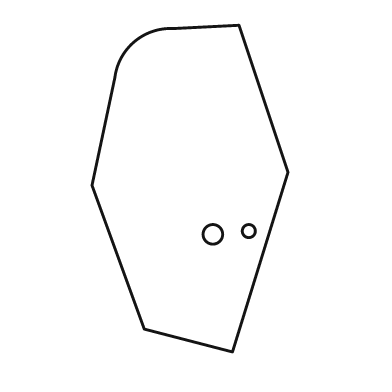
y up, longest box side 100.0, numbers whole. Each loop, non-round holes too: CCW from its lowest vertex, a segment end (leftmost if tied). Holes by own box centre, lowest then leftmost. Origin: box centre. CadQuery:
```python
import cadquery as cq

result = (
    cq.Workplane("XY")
    .moveTo(13.0, -50.0)
    .lineTo(30.0, 5.0)
    .lineTo(15.0, 50.0)
    .lineTo(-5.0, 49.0)
    .threePointArc((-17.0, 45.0), (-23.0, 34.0))
    .lineTo(-30.0, 1.0)
    .lineTo(-14.0, -43.0)
    .close()
    .moveTo(7.0, -14.0)
    .circle(3.0)
    .moveTo(18.0, -13.0)
    .circle(2.0)
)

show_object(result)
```